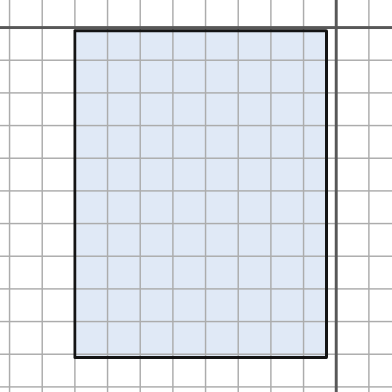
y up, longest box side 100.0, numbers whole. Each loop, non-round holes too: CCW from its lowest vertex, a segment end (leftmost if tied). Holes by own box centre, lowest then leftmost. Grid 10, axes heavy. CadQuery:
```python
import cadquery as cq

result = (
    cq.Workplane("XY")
    .moveTo(-80.0, -101.0)
    .lineTo(-3.0, -101.0)
    .lineTo(-3.0, -1.0)
    .lineTo(-80.0, -1.0)
    .close()
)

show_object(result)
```